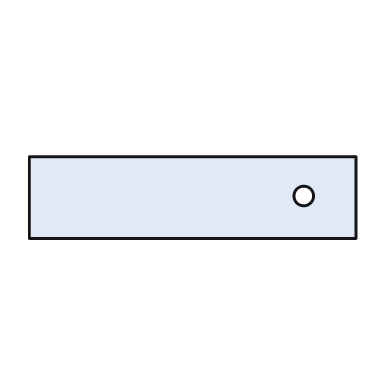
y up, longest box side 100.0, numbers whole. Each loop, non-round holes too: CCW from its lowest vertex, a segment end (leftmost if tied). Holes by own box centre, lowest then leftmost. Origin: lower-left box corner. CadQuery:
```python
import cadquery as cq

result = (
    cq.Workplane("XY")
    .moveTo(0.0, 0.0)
    .lineTo(100.0, 0.0)
    .lineTo(100.0, 25.0)
    .lineTo(0.0, 25.0)
    .close()
    .moveTo(84.0, 13.0)
    .circle(3.0)
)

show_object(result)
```